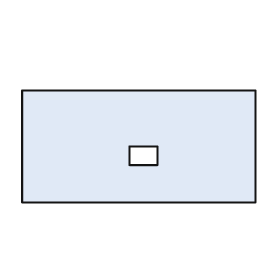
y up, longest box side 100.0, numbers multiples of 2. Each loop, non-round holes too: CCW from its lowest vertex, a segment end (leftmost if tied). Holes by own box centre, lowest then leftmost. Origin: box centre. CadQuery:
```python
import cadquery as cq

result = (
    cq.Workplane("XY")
    .moveTo(-50.0, -24.0)
    .lineTo(50.0, -24.0)
    .lineTo(50.0, 24.0)
    .lineTo(-50.0, 24.0)
    .close()
    .moveTo(-4.0, -8.0)
    .lineTo(8.0, -8.0)
    .lineTo(8.0, 0.0)
    .lineTo(-4.0, 0.0)
    .close()
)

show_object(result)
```